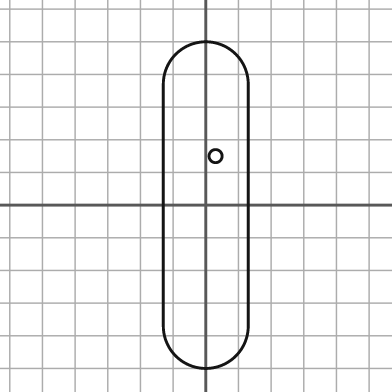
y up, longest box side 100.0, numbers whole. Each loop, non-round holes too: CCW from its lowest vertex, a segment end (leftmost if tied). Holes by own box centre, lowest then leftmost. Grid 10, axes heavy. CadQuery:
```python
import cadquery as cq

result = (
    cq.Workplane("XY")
    .moveTo(-13.0, -37.0)
    .threePointArc((0.0, -50.0), (13.0, -37.0))
    .lineTo(13.0, 37.0)
    .threePointArc((0.0, 50.0), (-13.0, 37.0))
    .close()
    .moveTo(3.0, 15.0)
    .circle(2.0)
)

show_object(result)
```